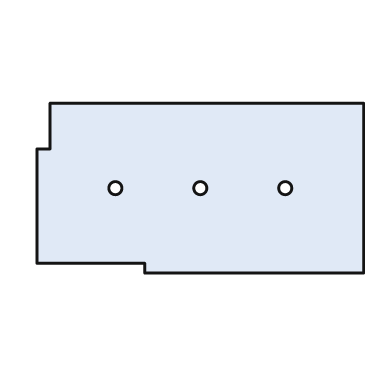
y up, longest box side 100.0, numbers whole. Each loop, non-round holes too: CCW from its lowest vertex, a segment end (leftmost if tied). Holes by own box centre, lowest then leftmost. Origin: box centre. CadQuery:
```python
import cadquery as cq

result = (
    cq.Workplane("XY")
    .moveTo(-17.0, -26.0)
    .lineTo(50.0, -26.0)
    .lineTo(50.0, 26.0)
    .lineTo(-46.0, 26.0)
    .lineTo(-46.0, 12.0)
    .lineTo(-50.0, 12.0)
    .lineTo(-50.0, -23.0)
    .lineTo(-17.0, -23.0)
    .close()
    .moveTo(-26.0, 0.0)
    .circle(2.0)
    .moveTo(0.0, 0.0)
    .circle(2.0)
    .moveTo(26.0, 0.0)
    .circle(2.0)
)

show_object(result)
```